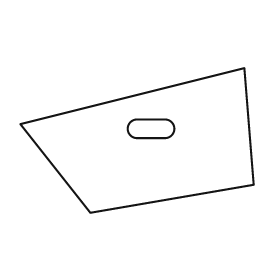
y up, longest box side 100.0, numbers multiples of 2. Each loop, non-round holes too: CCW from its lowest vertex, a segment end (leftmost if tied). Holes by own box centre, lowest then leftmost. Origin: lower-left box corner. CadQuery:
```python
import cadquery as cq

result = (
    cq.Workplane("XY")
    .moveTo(30.0, 0.0)
    .lineTo(100.0, 12.0)
    .lineTo(96.0, 62.0)
    .lineTo(0.0, 38.0)
    .close()
    .moveTo(50.0, 32.0)
    .lineTo(62.0, 32.0)
    .threePointArc((66.0, 36.0), (62.0, 40.0))
    .lineTo(50.0, 40.0)
    .threePointArc((46.0, 36.0), (50.0, 32.0))
    .close()
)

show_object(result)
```